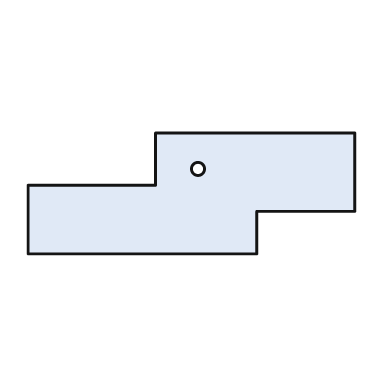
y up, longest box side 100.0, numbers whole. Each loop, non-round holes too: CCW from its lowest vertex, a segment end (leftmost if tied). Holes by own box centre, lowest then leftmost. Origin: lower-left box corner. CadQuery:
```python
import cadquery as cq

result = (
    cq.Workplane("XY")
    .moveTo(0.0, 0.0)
    .lineTo(70.0, 0.0)
    .lineTo(70.0, 13.0)
    .lineTo(100.0, 13.0)
    .lineTo(100.0, 37.0)
    .lineTo(39.0, 37.0)
    .lineTo(39.0, 21.0)
    .lineTo(0.0, 21.0)
    .close()
    .moveTo(52.0, 26.0)
    .circle(2.0)
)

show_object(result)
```